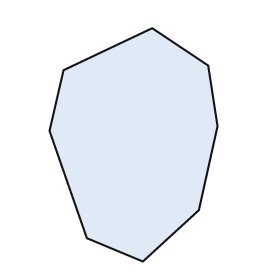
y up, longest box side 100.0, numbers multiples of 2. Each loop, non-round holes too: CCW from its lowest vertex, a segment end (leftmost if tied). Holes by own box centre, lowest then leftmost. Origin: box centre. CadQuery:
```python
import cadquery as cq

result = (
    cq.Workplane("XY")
    .moveTo(4.0, -50.0)
    .lineTo(28.0, -28.0)
    .lineTo(36.0, 8.0)
    .lineTo(32.0, 34.0)
    .lineTo(8.0, 50.0)
    .lineTo(-30.0, 32.0)
    .lineTo(-36.0, 6.0)
    .lineTo(-20.0, -40.0)
    .close()
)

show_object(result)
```